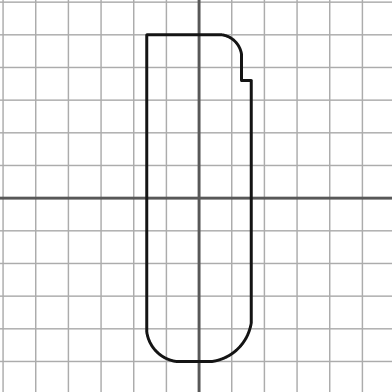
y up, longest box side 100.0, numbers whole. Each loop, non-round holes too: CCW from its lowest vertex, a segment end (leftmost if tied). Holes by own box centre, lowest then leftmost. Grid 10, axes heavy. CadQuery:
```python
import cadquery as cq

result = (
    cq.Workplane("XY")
    .moveTo(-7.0, -50.0)
    .lineTo(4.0, -50.0)
    .threePointArc((12.0, -46.0), (16.0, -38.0))
    .lineTo(16.0, 36.0)
    .lineTo(13.0, 36.0)
    .lineTo(13.0, 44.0)
    .threePointArc((11.0, 48.0), (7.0, 50.0))
    .lineTo(-16.0, 50.0)
    .lineTo(-16.0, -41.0)
    .threePointArc((-13.0, -47.0), (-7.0, -50.0))
    .close()
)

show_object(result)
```